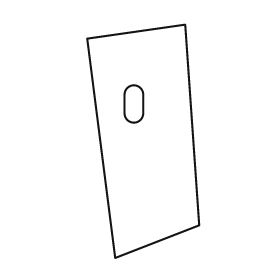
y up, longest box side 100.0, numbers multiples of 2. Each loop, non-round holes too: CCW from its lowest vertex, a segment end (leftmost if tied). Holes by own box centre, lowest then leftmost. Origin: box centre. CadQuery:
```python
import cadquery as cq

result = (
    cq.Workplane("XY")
    .moveTo(-12.0, -50.0)
    .lineTo(24.0, -36.0)
    .lineTo(18.0, 50.0)
    .lineTo(-24.0, 44.0)
    .close()
    .moveTo(-8.0, 12.0)
    .threePointArc((-4.0, 8.0), (0.0, 12.0))
    .lineTo(0.0, 20.0)
    .threePointArc((-4.0, 24.0), (-8.0, 20.0))
    .close()
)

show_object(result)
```